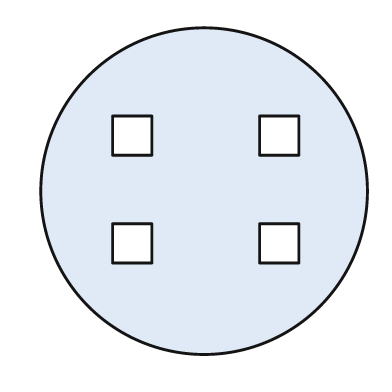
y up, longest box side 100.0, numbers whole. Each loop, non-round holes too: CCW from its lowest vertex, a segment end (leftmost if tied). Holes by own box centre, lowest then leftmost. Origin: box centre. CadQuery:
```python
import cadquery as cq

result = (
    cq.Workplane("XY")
    .moveTo(0.0, 0.0)
    .circle(50.0)
    .moveTo(-28.0, -22.0)
    .lineTo(-16.0, -22.0)
    .lineTo(-16.0, -10.0)
    .lineTo(-28.0, -10.0)
    .close()
    .moveTo(17.0, -22.0)
    .lineTo(29.0, -22.0)
    .lineTo(29.0, -10.0)
    .lineTo(17.0, -10.0)
    .close()
    .moveTo(-28.0, 11.0)
    .lineTo(-16.0, 11.0)
    .lineTo(-16.0, 23.0)
    .lineTo(-28.0, 23.0)
    .close()
    .moveTo(17.0, 11.0)
    .lineTo(29.0, 11.0)
    .lineTo(29.0, 23.0)
    .lineTo(17.0, 23.0)
    .close()
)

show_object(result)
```